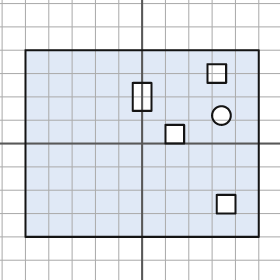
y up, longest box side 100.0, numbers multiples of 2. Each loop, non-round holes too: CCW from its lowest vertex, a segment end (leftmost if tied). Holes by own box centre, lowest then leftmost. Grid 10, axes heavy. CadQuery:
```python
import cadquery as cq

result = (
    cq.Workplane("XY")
    .moveTo(-50.0, -40.0)
    .lineTo(50.0, -40.0)
    .lineTo(50.0, 40.0)
    .lineTo(-50.0, 40.0)
    .close()
    .moveTo(32.0, -30.0)
    .lineTo(40.0, -30.0)
    .lineTo(40.0, -22.0)
    .lineTo(32.0, -22.0)
    .close()
    .moveTo(10.0, 0.0)
    .lineTo(18.0, 0.0)
    .lineTo(18.0, 8.0)
    .lineTo(10.0, 8.0)
    .close()
    .moveTo(34.0, 12.0)
    .circle(4.0)
    .moveTo(-4.0, 14.0)
    .lineTo(4.0, 14.0)
    .lineTo(4.0, 26.0)
    .lineTo(-4.0, 26.0)
    .close()
    .moveTo(28.0, 26.0)
    .lineTo(36.0, 26.0)
    .lineTo(36.0, 34.0)
    .lineTo(28.0, 34.0)
    .close()
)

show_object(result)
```